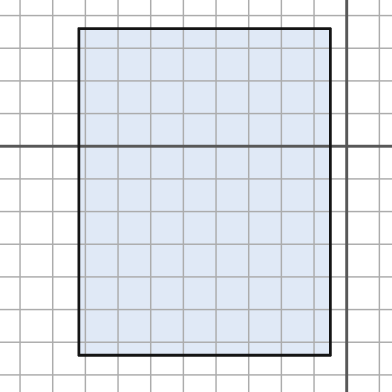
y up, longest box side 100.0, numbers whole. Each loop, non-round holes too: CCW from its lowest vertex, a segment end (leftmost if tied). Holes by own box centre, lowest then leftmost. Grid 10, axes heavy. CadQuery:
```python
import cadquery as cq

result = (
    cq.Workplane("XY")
    .moveTo(-82.0, -64.0)
    .lineTo(-5.0, -64.0)
    .lineTo(-5.0, 36.0)
    .lineTo(-82.0, 36.0)
    .close()
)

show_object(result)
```